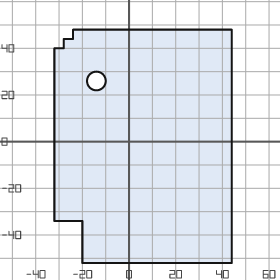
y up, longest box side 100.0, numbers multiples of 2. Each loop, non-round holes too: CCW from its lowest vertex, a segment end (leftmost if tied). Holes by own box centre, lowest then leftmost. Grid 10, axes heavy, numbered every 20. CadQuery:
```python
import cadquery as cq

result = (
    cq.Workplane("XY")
    .moveTo(-20.0, -52.0)
    .lineTo(44.0, -52.0)
    .lineTo(44.0, 48.0)
    .lineTo(-24.0, 48.0)
    .lineTo(-24.0, 44.0)
    .lineTo(-28.0, 44.0)
    .lineTo(-28.0, 40.0)
    .lineTo(-32.0, 40.0)
    .lineTo(-32.0, -34.0)
    .lineTo(-20.0, -34.0)
    .close()
    .moveTo(-14.0, 26.0)
    .circle(4.0)
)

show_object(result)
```